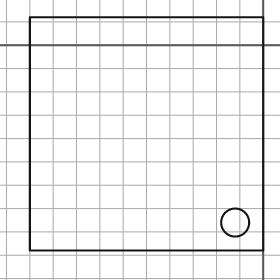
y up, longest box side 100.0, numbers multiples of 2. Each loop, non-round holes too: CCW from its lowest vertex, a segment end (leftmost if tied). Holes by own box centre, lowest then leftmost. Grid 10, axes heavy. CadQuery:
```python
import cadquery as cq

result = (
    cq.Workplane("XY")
    .moveTo(-100.0, -88.0)
    .lineTo(0.0, -88.0)
    .lineTo(0.0, 12.0)
    .lineTo(-100.0, 12.0)
    .close()
    .moveTo(-12.0, -76.0)
    .circle(6.0)
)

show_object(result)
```